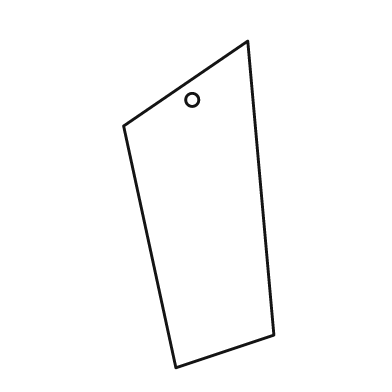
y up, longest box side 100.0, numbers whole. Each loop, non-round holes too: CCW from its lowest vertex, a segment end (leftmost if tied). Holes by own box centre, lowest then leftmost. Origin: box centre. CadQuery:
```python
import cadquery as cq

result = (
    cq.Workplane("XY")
    .moveTo(-7.0, -50.0)
    .lineTo(23.0, -40.0)
    .lineTo(15.0, 50.0)
    .lineTo(-23.0, 24.0)
    .close()
    .moveTo(-2.0, 32.0)
    .circle(2.0)
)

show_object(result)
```